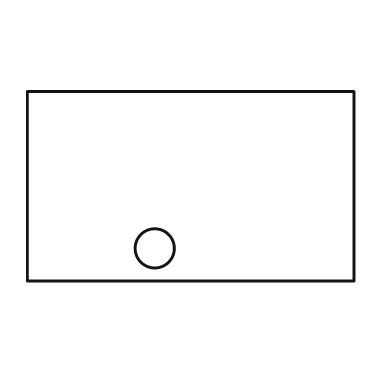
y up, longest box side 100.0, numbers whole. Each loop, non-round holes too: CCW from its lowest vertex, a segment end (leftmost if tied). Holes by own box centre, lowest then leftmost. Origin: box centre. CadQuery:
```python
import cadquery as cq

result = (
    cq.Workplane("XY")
    .moveTo(-50.0, -29.0)
    .lineTo(50.0, -29.0)
    .lineTo(50.0, 29.0)
    .lineTo(-50.0, 29.0)
    .close()
    .moveTo(-11.0, -19.0)
    .circle(6.0)
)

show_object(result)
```